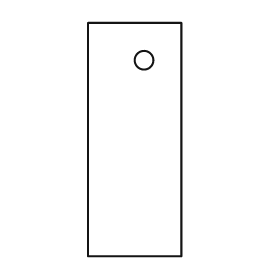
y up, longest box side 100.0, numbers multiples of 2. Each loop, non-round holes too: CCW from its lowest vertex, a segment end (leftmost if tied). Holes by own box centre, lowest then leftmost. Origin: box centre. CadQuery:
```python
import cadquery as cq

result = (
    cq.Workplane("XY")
    .moveTo(-20.0, -50.0)
    .lineTo(20.0, -50.0)
    .lineTo(20.0, 50.0)
    .lineTo(-20.0, 50.0)
    .close()
    .moveTo(4.0, 34.0)
    .circle(4.0)
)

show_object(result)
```